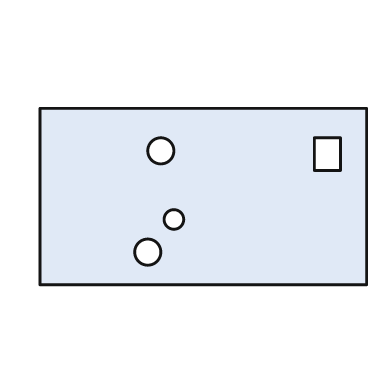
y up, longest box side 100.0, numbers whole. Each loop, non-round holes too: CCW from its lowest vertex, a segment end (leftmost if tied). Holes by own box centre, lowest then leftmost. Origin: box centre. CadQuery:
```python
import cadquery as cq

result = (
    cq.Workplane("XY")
    .moveTo(-50.0, -27.0)
    .lineTo(50.0, -27.0)
    .lineTo(50.0, 27.0)
    .lineTo(-50.0, 27.0)
    .close()
    .moveTo(-17.0, -17.0)
    .circle(4.0)
    .moveTo(-9.0, -7.0)
    .circle(3.0)
    .moveTo(34.0, 8.0)
    .lineTo(42.0, 8.0)
    .lineTo(42.0, 18.0)
    .lineTo(34.0, 18.0)
    .close()
    .moveTo(-13.0, 14.0)
    .circle(4.0)
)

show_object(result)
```